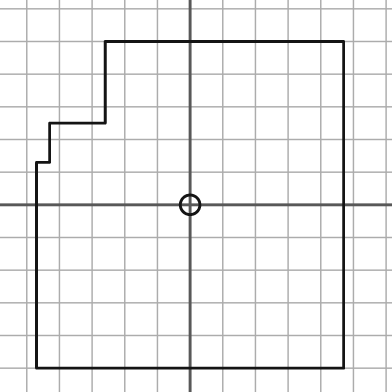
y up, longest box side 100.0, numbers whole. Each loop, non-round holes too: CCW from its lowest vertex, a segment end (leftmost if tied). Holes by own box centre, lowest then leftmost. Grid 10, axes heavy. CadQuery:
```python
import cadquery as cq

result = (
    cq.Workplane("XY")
    .moveTo(-47.0, -50.0)
    .lineTo(47.0, -50.0)
    .lineTo(47.0, 50.0)
    .lineTo(-26.0, 50.0)
    .lineTo(-26.0, 25.0)
    .lineTo(-43.0, 25.0)
    .lineTo(-43.0, 13.0)
    .lineTo(-47.0, 13.0)
    .close()
    .moveTo(0.0, 0.0)
    .circle(3.0)
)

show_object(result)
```